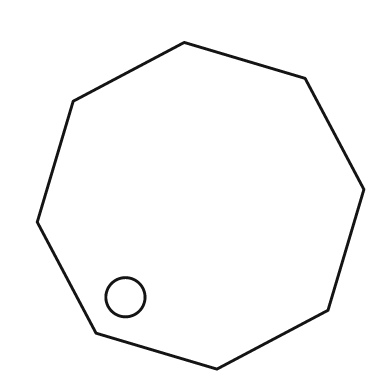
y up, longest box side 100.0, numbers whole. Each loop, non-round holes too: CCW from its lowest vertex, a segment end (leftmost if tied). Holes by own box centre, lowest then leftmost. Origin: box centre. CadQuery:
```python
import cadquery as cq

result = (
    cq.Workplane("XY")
    .moveTo(5.0, -50.0)
    .lineTo(39.0, -32.0)
    .lineTo(50.0, 5.0)
    .lineTo(32.0, 39.0)
    .lineTo(-5.0, 50.0)
    .lineTo(-39.0, 32.0)
    .lineTo(-50.0, -5.0)
    .lineTo(-32.0, -39.0)
    .close()
    .moveTo(-23.0, -28.0)
    .circle(6.0)
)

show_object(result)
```